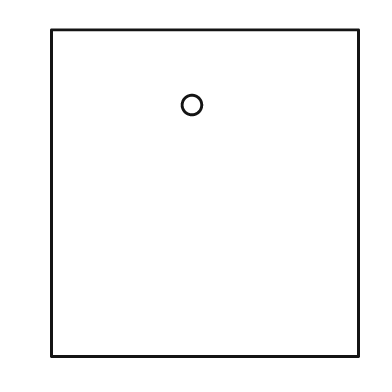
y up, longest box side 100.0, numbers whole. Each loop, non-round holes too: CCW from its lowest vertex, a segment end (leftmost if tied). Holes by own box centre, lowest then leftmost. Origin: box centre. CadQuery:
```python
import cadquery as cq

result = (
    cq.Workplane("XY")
    .moveTo(-47.0, -50.0)
    .lineTo(47.0, -50.0)
    .lineTo(47.0, 50.0)
    .lineTo(-47.0, 50.0)
    .close()
    .moveTo(-4.0, 27.0)
    .circle(3.0)
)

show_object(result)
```